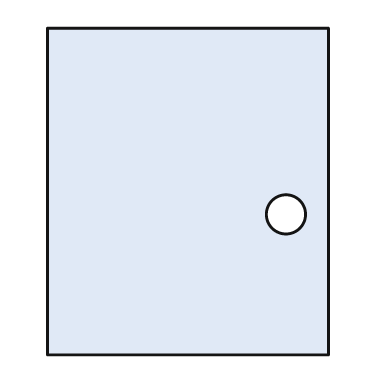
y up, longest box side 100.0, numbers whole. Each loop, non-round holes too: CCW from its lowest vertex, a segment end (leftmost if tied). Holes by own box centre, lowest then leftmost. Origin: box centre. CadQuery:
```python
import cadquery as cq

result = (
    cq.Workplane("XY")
    .moveTo(-43.0, -50.0)
    .lineTo(43.0, -50.0)
    .lineTo(43.0, 50.0)
    .lineTo(-43.0, 50.0)
    .close()
    .moveTo(30.0, -7.0)
    .circle(6.0)
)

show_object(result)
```